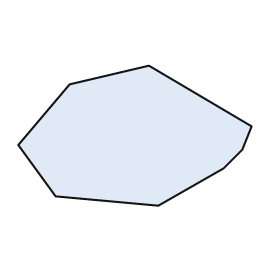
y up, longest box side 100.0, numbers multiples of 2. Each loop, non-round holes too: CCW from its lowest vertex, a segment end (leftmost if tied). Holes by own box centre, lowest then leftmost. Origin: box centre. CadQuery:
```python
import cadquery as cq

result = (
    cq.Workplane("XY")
    .moveTo(10.0, -30.0)
    .lineTo(38.0, -14.0)
    .lineTo(46.0, -6.0)
    .lineTo(50.0, 4.0)
    .lineTo(6.0, 30.0)
    .lineTo(-28.0, 22.0)
    .lineTo(-50.0, -4.0)
    .lineTo(-34.0, -26.0)
    .close()
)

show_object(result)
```